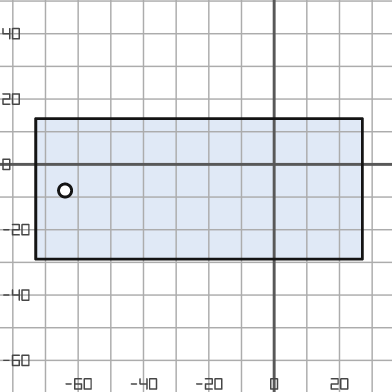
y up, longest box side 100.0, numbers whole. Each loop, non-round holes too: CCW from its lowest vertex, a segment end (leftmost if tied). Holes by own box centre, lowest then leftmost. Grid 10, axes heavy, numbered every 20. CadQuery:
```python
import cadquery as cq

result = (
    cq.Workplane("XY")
    .moveTo(-73.0, -29.0)
    .lineTo(27.0, -29.0)
    .lineTo(27.0, 14.0)
    .lineTo(-73.0, 14.0)
    .close()
    .moveTo(-64.0, -8.0)
    .circle(2.0)
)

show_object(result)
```